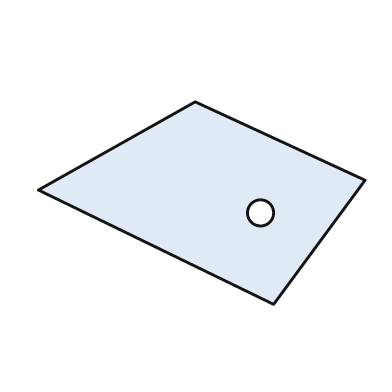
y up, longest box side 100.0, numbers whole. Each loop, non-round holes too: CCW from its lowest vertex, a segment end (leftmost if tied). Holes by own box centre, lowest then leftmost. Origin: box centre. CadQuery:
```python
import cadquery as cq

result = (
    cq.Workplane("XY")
    .moveTo(22.0, -31.0)
    .lineTo(50.0, 7.0)
    .lineTo(-2.0, 31.0)
    .lineTo(-50.0, 4.0)
    .close()
    .moveTo(18.0, -3.0)
    .circle(4.0)
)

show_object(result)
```